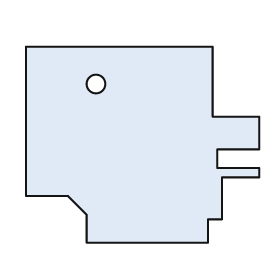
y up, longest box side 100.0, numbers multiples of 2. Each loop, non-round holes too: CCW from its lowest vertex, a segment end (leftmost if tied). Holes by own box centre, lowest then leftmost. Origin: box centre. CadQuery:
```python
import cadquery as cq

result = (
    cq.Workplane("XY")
    .moveTo(-24.0, -42.0)
    .lineTo(28.0, -42.0)
    .lineTo(28.0, -32.0)
    .lineTo(34.0, -32.0)
    .lineTo(34.0, -14.0)
    .lineTo(50.0, -14.0)
    .lineTo(50.0, -10.0)
    .lineTo(32.0, -10.0)
    .lineTo(32.0, -2.0)
    .lineTo(50.0, -2.0)
    .lineTo(50.0, 12.0)
    .lineTo(30.0, 12.0)
    .lineTo(30.0, 42.0)
    .lineTo(-50.0, 42.0)
    .lineTo(-50.0, -22.0)
    .lineTo(-32.0, -22.0)
    .lineTo(-24.0, -30.0)
    .close()
    .moveTo(-20.0, 26.0)
    .circle(4.0)
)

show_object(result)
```